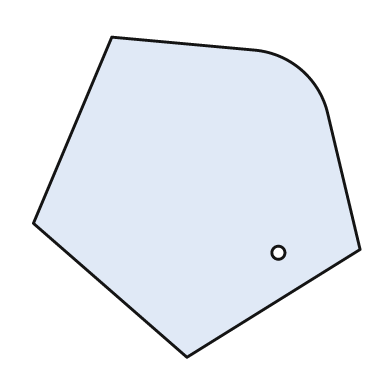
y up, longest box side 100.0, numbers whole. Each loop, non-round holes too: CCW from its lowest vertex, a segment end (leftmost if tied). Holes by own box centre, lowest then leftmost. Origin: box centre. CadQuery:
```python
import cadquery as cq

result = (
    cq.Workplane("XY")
    .moveTo(-3.0, -49.0)
    .lineTo(50.0, -16.0)
    .lineTo(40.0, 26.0)
    .threePointArc((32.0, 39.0), (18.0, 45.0))
    .lineTo(-26.0, 49.0)
    .lineTo(-50.0, -8.0)
    .close()
    .moveTo(25.0, -17.0)
    .circle(2.0)
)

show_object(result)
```